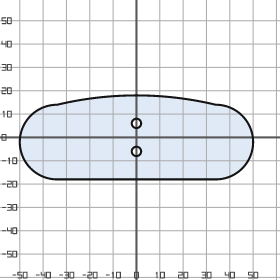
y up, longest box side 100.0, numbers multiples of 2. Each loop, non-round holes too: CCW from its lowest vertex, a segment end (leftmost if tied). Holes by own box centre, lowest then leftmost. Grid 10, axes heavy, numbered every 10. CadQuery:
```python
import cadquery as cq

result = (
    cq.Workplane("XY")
    .moveTo(-34.0, -18.0)
    .lineTo(34.0, -18.0)
    .threePointArc((50.0, -2.0), (34.0, 14.0))
    .threePointArc((0.0, 18.0), (-34.0, 14.0))
    .threePointArc((-50.0, -2.0), (-34.0, -18.0))
    .close()
    .moveTo(0.0, -6.0)
    .circle(2.0)
    .moveTo(0.0, 6.0)
    .circle(2.0)
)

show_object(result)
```